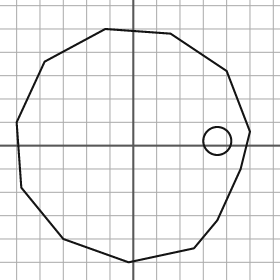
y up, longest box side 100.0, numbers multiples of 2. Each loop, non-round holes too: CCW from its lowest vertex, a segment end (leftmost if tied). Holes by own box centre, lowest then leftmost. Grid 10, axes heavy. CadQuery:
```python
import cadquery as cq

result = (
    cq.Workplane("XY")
    .moveTo(-2.0, -50.0)
    .lineTo(26.0, -44.0)
    .lineTo(36.0, -32.0)
    .lineTo(46.0, -10.0)
    .lineTo(50.0, 6.0)
    .lineTo(40.0, 32.0)
    .lineTo(16.0, 48.0)
    .lineTo(-12.0, 50.0)
    .lineTo(-38.0, 36.0)
    .lineTo(-50.0, 10.0)
    .lineTo(-48.0, -18.0)
    .lineTo(-30.0, -40.0)
    .close()
    .moveTo(36.0, 2.0)
    .circle(6.0)
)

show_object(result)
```